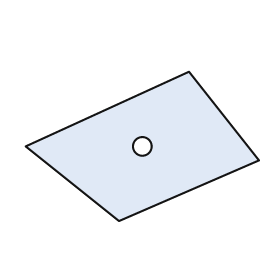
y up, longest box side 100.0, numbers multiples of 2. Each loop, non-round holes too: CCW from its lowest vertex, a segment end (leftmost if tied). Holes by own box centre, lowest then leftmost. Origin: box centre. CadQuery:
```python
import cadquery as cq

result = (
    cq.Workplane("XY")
    .moveTo(-10.0, -32.0)
    .lineTo(50.0, -6.0)
    .lineTo(20.0, 32.0)
    .lineTo(-50.0, 0.0)
    .close()
    .moveTo(0.0, 0.0)
    .circle(4.0)
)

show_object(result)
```